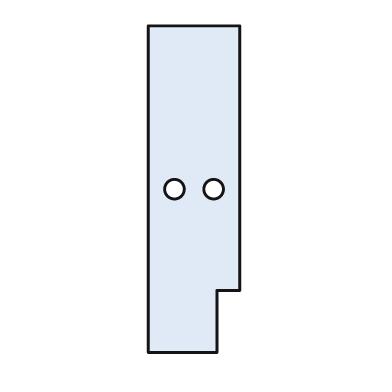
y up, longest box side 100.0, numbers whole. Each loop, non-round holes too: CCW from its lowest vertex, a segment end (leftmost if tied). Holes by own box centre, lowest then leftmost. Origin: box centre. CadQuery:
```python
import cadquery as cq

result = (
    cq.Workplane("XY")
    .moveTo(-14.0, -50.0)
    .lineTo(7.0, -50.0)
    .lineTo(7.0, -31.0)
    .lineTo(14.0, -31.0)
    .lineTo(14.0, 50.0)
    .lineTo(-14.0, 50.0)
    .close()
    .moveTo(-6.0, 0.0)
    .circle(3.0)
    .moveTo(6.0, 0.0)
    .circle(3.0)
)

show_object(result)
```